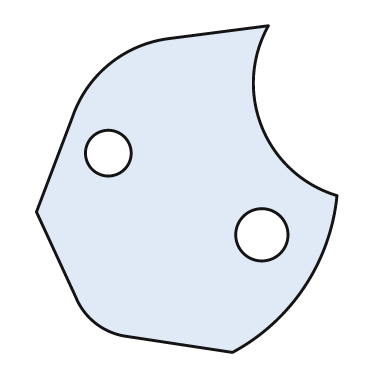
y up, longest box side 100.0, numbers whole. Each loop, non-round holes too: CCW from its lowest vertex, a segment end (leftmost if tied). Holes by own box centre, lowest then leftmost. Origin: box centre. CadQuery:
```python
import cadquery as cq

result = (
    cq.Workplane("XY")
    .moveTo(14.0, -50.0)
    .threePointArc((36.0, -30.0), (46.0, -2.0))
    .threePointArc((23.0, 19.0), (25.0, 50.0))
    .lineTo(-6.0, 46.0)
    .threePointArc((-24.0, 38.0), (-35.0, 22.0))
    .lineTo(-46.0, -7.0)
    .lineTo(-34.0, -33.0)
    .threePointArc((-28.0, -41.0), (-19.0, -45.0))
    .close()
    .moveTo(23.0, -14.0)
    .circle(8.0)
    .moveTo(-24.0, 11.0)
    .circle(7.0)
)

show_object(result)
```